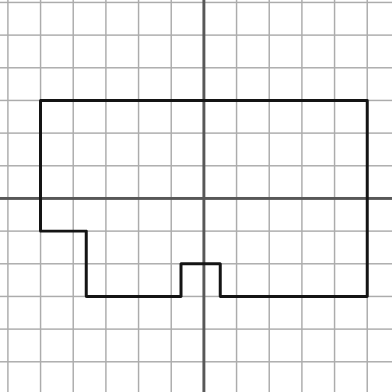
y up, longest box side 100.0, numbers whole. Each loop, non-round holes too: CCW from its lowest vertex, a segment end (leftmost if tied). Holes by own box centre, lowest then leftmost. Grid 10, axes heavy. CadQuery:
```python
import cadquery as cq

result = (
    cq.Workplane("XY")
    .moveTo(-36.0, -30.0)
    .lineTo(-7.0, -30.0)
    .lineTo(-7.0, -20.0)
    .lineTo(5.0, -20.0)
    .lineTo(5.0, -30.0)
    .lineTo(50.0, -30.0)
    .lineTo(50.0, 30.0)
    .lineTo(-50.0, 30.0)
    .lineTo(-50.0, -10.0)
    .lineTo(-36.0, -10.0)
    .close()
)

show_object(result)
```